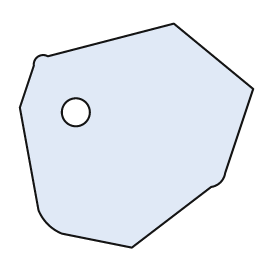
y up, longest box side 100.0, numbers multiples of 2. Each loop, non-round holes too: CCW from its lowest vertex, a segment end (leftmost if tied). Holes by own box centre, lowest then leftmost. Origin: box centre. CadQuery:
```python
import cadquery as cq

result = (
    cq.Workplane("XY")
    .moveTo(-2.0, -48.0)
    .lineTo(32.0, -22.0)
    .threePointArc((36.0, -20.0), (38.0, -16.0))
    .lineTo(50.0, 20.0)
    .lineTo(16.0, 48.0)
    .lineTo(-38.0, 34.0)
    .threePointArc((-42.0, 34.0), (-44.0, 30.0))
    .lineTo(-50.0, 12.0)
    .lineTo(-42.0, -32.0)
    .threePointArc((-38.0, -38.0), (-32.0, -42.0))
    .close()
    .moveTo(-26.0, 10.0)
    .circle(6.0)
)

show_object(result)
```